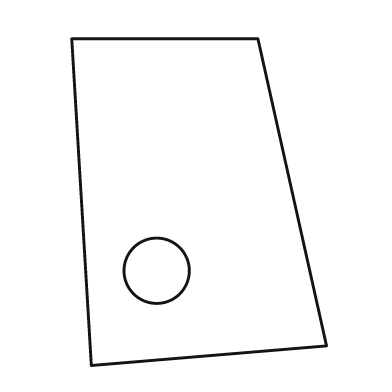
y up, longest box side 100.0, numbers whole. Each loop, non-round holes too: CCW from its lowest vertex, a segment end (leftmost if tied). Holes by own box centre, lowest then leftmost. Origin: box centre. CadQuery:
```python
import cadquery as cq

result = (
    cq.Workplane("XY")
    .moveTo(-33.0, -50.0)
    .lineTo(39.0, -44.0)
    .lineTo(18.0, 50.0)
    .lineTo(-39.0, 50.0)
    .close()
    .moveTo(-13.0, -21.0)
    .circle(10.0)
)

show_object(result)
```